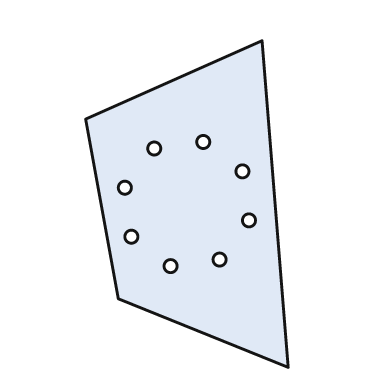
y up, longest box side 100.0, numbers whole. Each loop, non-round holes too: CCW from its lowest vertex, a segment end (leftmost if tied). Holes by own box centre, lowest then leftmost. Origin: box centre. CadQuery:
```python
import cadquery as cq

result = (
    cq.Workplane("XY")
    .moveTo(31.0, -50.0)
    .lineTo(23.0, 50.0)
    .lineTo(-31.0, 26.0)
    .lineTo(-21.0, -29.0)
    .close()
    .moveTo(-5.0, -19.0)
    .circle(2.0)
    .moveTo(10.0, -17.0)
    .circle(2.0)
    .moveTo(-17.0, -10.0)
    .circle(2.0)
    .moveTo(19.0, -5.0)
    .circle(2.0)
    .moveTo(-19.0, 5.0)
    .circle(2.0)
    .moveTo(17.0, 10.0)
    .circle(2.0)
    .moveTo(-10.0, 17.0)
    .circle(2.0)
    .moveTo(5.0, 19.0)
    .circle(2.0)
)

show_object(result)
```